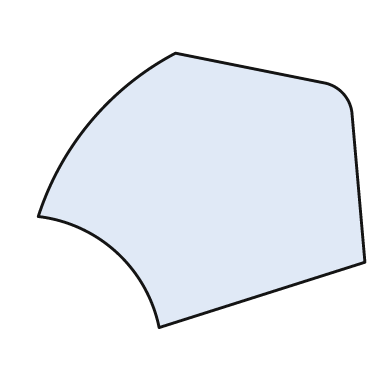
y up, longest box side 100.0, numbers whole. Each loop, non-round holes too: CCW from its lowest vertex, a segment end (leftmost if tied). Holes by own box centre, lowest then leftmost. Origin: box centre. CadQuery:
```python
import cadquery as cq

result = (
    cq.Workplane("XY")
    .moveTo(-13.0, -42.0)
    .lineTo(50.0, -22.0)
    .lineTo(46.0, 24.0)
    .threePointArc((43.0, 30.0), (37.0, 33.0))
    .lineTo(-8.0, 42.0)
    .threePointArc((-34.0, 21.0), (-50.0, -8.0))
    .threePointArc((-26.0, -19.0), (-13.0, -42.0))
    .close()
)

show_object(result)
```